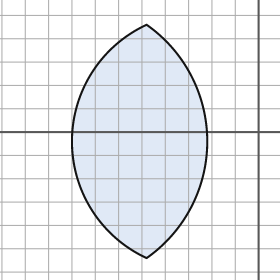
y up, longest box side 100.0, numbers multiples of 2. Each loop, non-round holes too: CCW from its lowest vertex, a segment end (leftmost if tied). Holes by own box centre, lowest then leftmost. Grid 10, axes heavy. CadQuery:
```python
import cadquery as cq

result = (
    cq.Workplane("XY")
    .moveTo(-48.0, -54.0)
    .threePointArc((-22.0, -4.0), (-48.0, 46.0))
    .threePointArc((-80.0, -4.0), (-48.0, -54.0))
    .close()
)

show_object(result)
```